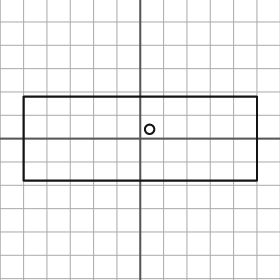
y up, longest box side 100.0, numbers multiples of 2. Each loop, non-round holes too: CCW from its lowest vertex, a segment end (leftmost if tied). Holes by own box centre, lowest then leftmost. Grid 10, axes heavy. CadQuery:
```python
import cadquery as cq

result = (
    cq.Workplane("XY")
    .moveTo(-50.0, -18.0)
    .lineTo(50.0, -18.0)
    .lineTo(50.0, 18.0)
    .lineTo(-50.0, 18.0)
    .close()
    .moveTo(4.0, 4.0)
    .circle(2.0)
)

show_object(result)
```